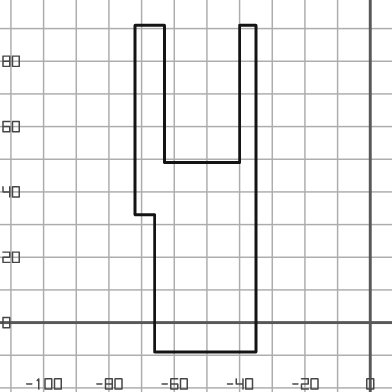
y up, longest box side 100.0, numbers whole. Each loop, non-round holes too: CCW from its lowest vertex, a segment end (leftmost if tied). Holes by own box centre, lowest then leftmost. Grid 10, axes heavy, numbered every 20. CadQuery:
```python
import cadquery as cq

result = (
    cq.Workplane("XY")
    .moveTo(-66.0, -9.0)
    .lineTo(-35.0, -9.0)
    .lineTo(-35.0, 91.0)
    .lineTo(-40.0, 91.0)
    .lineTo(-40.0, 49.0)
    .lineTo(-63.0, 49.0)
    .lineTo(-63.0, 91.0)
    .lineTo(-72.0, 91.0)
    .lineTo(-72.0, 33.0)
    .lineTo(-66.0, 33.0)
    .close()
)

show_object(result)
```